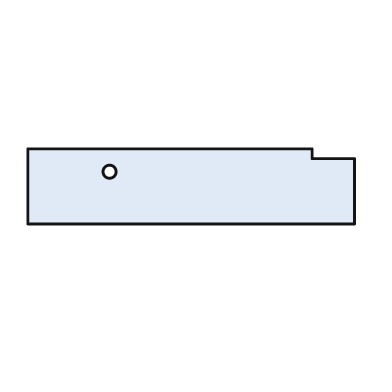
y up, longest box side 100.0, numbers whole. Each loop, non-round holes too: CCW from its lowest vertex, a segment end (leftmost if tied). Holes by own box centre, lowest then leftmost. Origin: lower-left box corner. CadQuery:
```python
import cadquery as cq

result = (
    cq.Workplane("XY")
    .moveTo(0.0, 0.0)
    .lineTo(100.0, 0.0)
    .lineTo(100.0, 20.0)
    .lineTo(87.0, 20.0)
    .lineTo(87.0, 23.0)
    .lineTo(0.0, 23.0)
    .close()
    .moveTo(25.0, 16.0)
    .circle(2.0)
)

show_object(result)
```